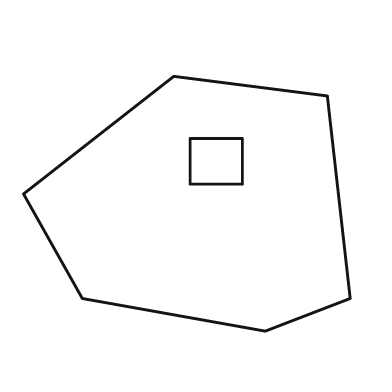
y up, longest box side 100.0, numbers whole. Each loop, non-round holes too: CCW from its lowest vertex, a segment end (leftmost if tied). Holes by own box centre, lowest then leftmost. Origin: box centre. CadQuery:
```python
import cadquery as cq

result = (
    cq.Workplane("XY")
    .moveTo(24.0, -39.0)
    .lineTo(50.0, -29.0)
    .lineTo(43.0, 33.0)
    .lineTo(-4.0, 39.0)
    .lineTo(-50.0, 3.0)
    .lineTo(-32.0, -29.0)
    .close()
    .moveTo(1.0, 6.0)
    .lineTo(17.0, 6.0)
    .lineTo(17.0, 20.0)
    .lineTo(1.0, 20.0)
    .close()
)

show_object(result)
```